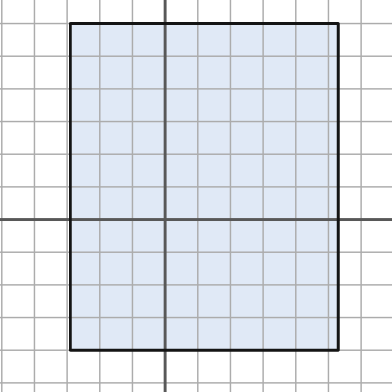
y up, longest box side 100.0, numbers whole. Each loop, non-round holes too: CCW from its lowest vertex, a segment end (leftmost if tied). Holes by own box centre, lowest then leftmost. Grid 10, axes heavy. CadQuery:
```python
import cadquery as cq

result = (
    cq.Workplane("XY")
    .moveTo(-29.0, -40.0)
    .lineTo(53.0, -40.0)
    .lineTo(53.0, 60.0)
    .lineTo(-29.0, 60.0)
    .close()
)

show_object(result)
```